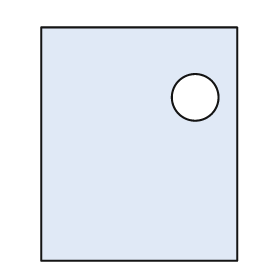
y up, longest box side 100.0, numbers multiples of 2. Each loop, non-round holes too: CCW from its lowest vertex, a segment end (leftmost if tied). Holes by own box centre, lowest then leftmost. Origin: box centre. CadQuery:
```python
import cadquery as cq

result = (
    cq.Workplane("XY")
    .moveTo(-42.0, -50.0)
    .lineTo(42.0, -50.0)
    .lineTo(42.0, 50.0)
    .lineTo(-42.0, 50.0)
    .close()
    .moveTo(24.0, 20.0)
    .circle(10.0)
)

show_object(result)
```